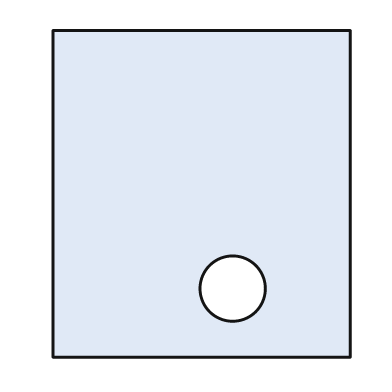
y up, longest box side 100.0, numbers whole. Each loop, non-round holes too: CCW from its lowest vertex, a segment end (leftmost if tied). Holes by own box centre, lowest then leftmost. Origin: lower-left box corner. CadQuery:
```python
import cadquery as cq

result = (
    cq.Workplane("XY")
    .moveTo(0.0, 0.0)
    .lineTo(91.0, 0.0)
    .lineTo(91.0, 100.0)
    .lineTo(0.0, 100.0)
    .close()
    .moveTo(55.0, 21.0)
    .circle(10.0)
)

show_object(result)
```